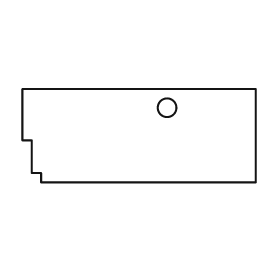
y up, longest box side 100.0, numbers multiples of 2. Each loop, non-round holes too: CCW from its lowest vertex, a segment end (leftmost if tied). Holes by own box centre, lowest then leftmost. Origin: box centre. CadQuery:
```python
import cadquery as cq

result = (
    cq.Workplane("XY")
    .moveTo(-42.0, -20.0)
    .lineTo(50.0, -20.0)
    .lineTo(50.0, 20.0)
    .lineTo(-50.0, 20.0)
    .lineTo(-50.0, -2.0)
    .lineTo(-46.0, -2.0)
    .lineTo(-46.0, -16.0)
    .lineTo(-42.0, -16.0)
    .close()
    .moveTo(12.0, 12.0)
    .circle(4.0)
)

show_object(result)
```